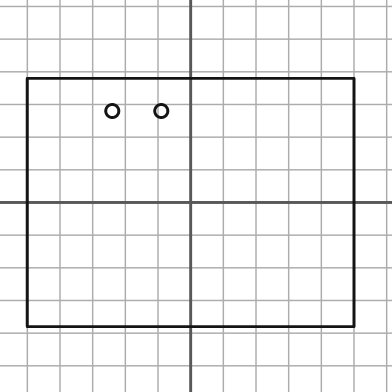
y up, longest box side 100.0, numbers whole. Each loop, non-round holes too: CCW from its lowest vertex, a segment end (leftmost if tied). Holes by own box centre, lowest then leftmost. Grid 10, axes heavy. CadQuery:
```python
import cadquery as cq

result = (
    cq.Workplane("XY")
    .moveTo(-50.0, -38.0)
    .lineTo(50.0, -38.0)
    .lineTo(50.0, 38.0)
    .lineTo(-50.0, 38.0)
    .close()
    .moveTo(-24.0, 28.0)
    .circle(2.0)
    .moveTo(-9.0, 28.0)
    .circle(2.0)
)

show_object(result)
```